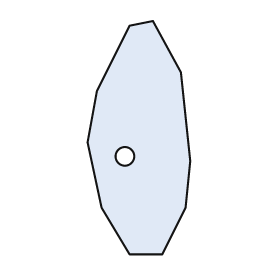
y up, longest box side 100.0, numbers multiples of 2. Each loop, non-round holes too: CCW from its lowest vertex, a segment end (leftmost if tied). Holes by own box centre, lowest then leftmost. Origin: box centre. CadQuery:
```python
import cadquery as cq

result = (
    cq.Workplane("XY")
    .moveTo(-4.0, -50.0)
    .lineTo(10.0, -50.0)
    .lineTo(20.0, -30.0)
    .lineTo(22.0, -10.0)
    .lineTo(18.0, 28.0)
    .lineTo(6.0, 50.0)
    .lineTo(-4.0, 48.0)
    .lineTo(-18.0, 20.0)
    .lineTo(-22.0, -2.0)
    .lineTo(-16.0, -30.0)
    .close()
    .moveTo(-6.0, -8.0)
    .circle(4.0)
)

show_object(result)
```